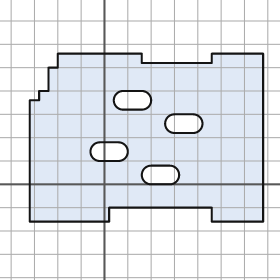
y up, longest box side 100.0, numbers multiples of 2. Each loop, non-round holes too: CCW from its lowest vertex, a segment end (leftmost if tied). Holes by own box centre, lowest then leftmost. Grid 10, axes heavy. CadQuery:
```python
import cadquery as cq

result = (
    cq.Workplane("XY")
    .moveTo(-32.0, -16.0)
    .lineTo(2.0, -16.0)
    .lineTo(2.0, -10.0)
    .lineTo(46.0, -10.0)
    .lineTo(46.0, -16.0)
    .lineTo(68.0, -16.0)
    .lineTo(68.0, 56.0)
    .lineTo(46.0, 56.0)
    .lineTo(46.0, 52.0)
    .lineTo(16.0, 52.0)
    .lineTo(16.0, 56.0)
    .lineTo(-20.0, 56.0)
    .lineTo(-20.0, 50.0)
    .lineTo(-24.0, 50.0)
    .lineTo(-24.0, 40.0)
    .lineTo(-28.0, 40.0)
    .lineTo(-28.0, 36.0)
    .lineTo(-32.0, 36.0)
    .close()
    .moveTo(20.0, 0.0)
    .lineTo(28.0, 0.0)
    .threePointArc((32.0, 4.0), (28.0, 8.0))
    .lineTo(20.0, 8.0)
    .threePointArc((16.0, 4.0), (20.0, 0.0))
    .close()
    .moveTo(-2.0, 10.0)
    .lineTo(6.0, 10.0)
    .threePointArc((10.0, 14.0), (6.0, 18.0))
    .lineTo(-2.0, 18.0)
    .threePointArc((-6.0, 14.0), (-2.0, 10.0))
    .close()
    .moveTo(30.0, 22.0)
    .lineTo(38.0, 22.0)
    .threePointArc((42.0, 26.0), (38.0, 30.0))
    .lineTo(30.0, 30.0)
    .threePointArc((26.0, 26.0), (30.0, 22.0))
    .close()
    .moveTo(8.0, 32.0)
    .lineTo(16.0, 32.0)
    .threePointArc((20.0, 36.0), (16.0, 40.0))
    .lineTo(8.0, 40.0)
    .threePointArc((4.0, 36.0), (8.0, 32.0))
    .close()
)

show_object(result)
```